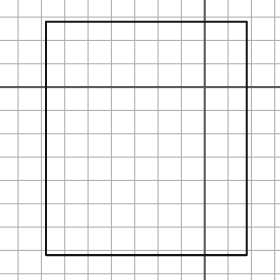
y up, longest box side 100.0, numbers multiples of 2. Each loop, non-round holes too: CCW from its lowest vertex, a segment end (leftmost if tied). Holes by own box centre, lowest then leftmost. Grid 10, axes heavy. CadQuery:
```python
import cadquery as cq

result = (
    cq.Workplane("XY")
    .moveTo(-68.0, -72.0)
    .lineTo(18.0, -72.0)
    .lineTo(18.0, 28.0)
    .lineTo(-68.0, 28.0)
    .close()
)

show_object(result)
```